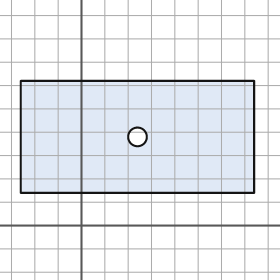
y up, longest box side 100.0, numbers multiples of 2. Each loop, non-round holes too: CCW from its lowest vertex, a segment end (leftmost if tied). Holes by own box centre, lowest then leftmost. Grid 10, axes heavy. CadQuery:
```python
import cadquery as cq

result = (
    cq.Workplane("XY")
    .moveTo(-26.0, 14.0)
    .lineTo(74.0, 14.0)
    .lineTo(74.0, 62.0)
    .lineTo(-26.0, 62.0)
    .close()
    .moveTo(24.0, 38.0)
    .circle(4.0)
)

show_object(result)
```